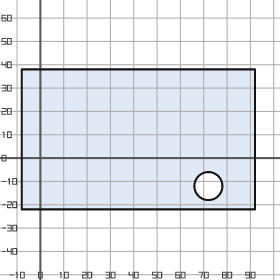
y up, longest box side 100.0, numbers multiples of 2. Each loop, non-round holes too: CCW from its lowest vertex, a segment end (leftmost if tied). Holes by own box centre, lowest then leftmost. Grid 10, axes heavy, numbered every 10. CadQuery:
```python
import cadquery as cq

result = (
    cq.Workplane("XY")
    .moveTo(-8.0, -22.0)
    .lineTo(92.0, -22.0)
    .lineTo(92.0, 38.0)
    .lineTo(-8.0, 38.0)
    .close()
    .moveTo(72.0, -12.0)
    .circle(6.0)
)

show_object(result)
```